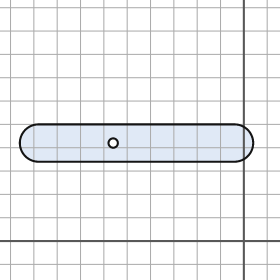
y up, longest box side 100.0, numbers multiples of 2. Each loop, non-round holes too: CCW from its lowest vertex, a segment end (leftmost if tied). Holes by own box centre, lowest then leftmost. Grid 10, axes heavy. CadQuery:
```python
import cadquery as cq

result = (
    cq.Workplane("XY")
    .moveTo(-88.0, 34.0)
    .lineTo(-4.0, 34.0)
    .threePointArc((4.0, 42.0), (-4.0, 50.0))
    .lineTo(-88.0, 50.0)
    .threePointArc((-96.0, 42.0), (-88.0, 34.0))
    .close()
    .moveTo(-56.0, 42.0)
    .circle(2.0)
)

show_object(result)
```